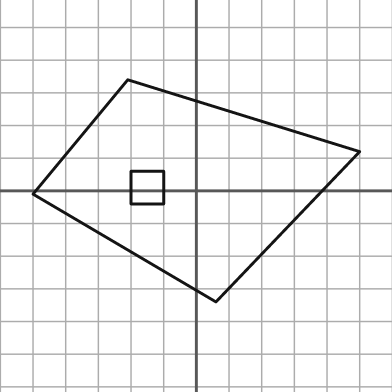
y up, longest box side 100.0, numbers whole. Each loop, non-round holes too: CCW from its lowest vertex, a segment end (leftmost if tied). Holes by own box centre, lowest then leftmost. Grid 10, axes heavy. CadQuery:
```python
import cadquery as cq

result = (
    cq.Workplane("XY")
    .moveTo(6.0, -34.0)
    .lineTo(50.0, 12.0)
    .lineTo(-21.0, 34.0)
    .lineTo(-50.0, -1.0)
    .close()
    .moveTo(-20.0, -4.0)
    .lineTo(-10.0, -4.0)
    .lineTo(-10.0, 6.0)
    .lineTo(-20.0, 6.0)
    .close()
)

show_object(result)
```